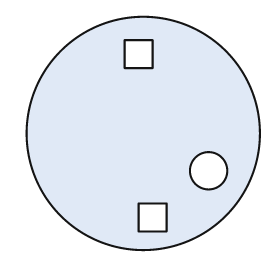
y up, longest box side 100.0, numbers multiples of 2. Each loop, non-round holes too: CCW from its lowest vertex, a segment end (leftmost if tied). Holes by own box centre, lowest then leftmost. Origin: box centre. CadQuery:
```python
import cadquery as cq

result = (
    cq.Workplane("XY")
    .moveTo(0.0, 0.0)
    .circle(50.0)
    .moveTo(-2.0, -42.0)
    .lineTo(10.0, -42.0)
    .lineTo(10.0, -30.0)
    .lineTo(-2.0, -30.0)
    .close()
    .moveTo(28.0, -16.0)
    .circle(8.0)
    .moveTo(-8.0, 28.0)
    .lineTo(4.0, 28.0)
    .lineTo(4.0, 40.0)
    .lineTo(-8.0, 40.0)
    .close()
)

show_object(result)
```